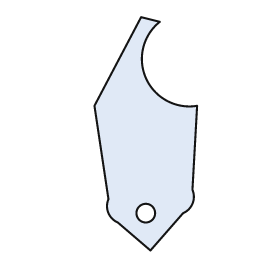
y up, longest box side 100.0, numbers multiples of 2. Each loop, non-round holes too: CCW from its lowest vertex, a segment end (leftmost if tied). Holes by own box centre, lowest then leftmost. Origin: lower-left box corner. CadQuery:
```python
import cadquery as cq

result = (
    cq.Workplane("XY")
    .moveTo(24.0, 0.0)
    .lineTo(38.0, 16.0)
    .threePointArc((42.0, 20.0), (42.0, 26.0))
    .lineTo(44.0, 62.0)
    .threePointArc((22.0, 74.0), (28.0, 98.0))
    .lineTo(20.0, 100.0)
    .lineTo(0.0, 62.0)
    .lineTo(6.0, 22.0)
    .threePointArc((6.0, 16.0), (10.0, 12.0))
    .close()
    .moveTo(22.0, 16.0)
    .circle(4.0)
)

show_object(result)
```